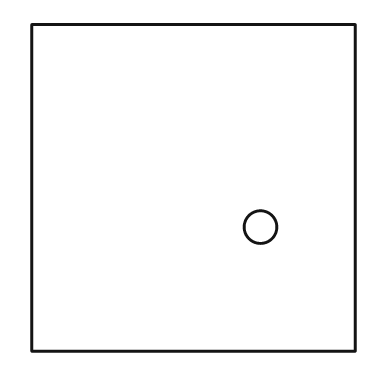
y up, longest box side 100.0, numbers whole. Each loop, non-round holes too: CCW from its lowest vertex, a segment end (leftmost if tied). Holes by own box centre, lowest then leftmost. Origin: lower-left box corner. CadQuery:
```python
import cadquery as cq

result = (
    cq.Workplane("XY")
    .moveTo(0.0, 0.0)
    .lineTo(99.0, 0.0)
    .lineTo(99.0, 100.0)
    .lineTo(0.0, 100.0)
    .close()
    .moveTo(70.0, 38.0)
    .circle(5.0)
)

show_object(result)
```